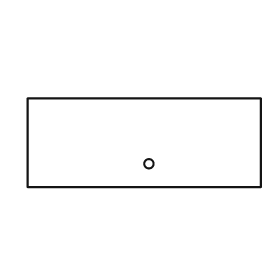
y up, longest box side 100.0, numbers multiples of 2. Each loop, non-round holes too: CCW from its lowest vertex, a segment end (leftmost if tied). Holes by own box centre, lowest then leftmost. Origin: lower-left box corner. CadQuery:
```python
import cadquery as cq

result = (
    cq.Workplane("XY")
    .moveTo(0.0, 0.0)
    .lineTo(100.0, 0.0)
    .lineTo(100.0, 38.0)
    .lineTo(0.0, 38.0)
    .close()
    .moveTo(52.0, 10.0)
    .circle(2.0)
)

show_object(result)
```